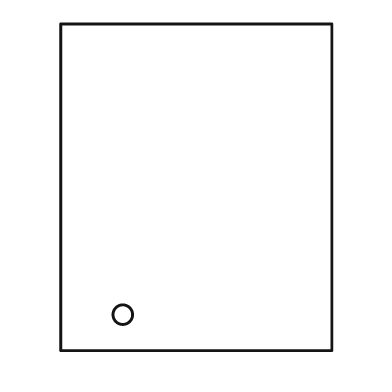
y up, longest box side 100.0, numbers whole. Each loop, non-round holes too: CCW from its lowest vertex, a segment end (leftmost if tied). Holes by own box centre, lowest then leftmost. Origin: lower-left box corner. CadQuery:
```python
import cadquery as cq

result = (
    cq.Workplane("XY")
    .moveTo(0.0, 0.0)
    .lineTo(83.0, 0.0)
    .lineTo(83.0, 100.0)
    .lineTo(0.0, 100.0)
    .close()
    .moveTo(19.0, 11.0)
    .circle(3.0)
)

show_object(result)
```